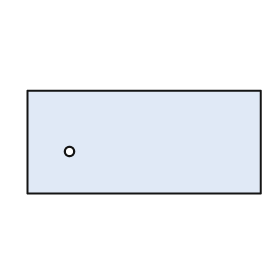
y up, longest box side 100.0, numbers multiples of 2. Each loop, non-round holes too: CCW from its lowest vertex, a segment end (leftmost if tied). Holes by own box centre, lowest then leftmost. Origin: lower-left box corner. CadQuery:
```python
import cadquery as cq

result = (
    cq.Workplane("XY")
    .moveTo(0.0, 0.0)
    .lineTo(100.0, 0.0)
    .lineTo(100.0, 44.0)
    .lineTo(0.0, 44.0)
    .close()
    .moveTo(18.0, 18.0)
    .circle(2.0)
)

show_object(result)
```